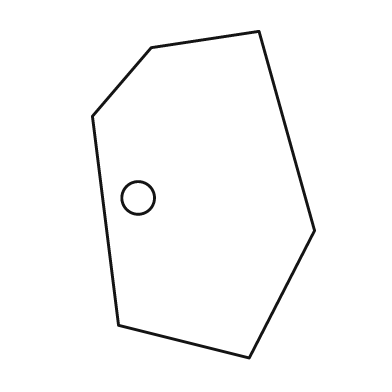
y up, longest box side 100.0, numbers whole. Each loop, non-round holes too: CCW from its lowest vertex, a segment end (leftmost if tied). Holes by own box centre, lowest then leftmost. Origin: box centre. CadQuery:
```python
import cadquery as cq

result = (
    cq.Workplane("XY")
    .moveTo(14.0, -50.0)
    .lineTo(34.0, -11.0)
    .lineTo(17.0, 50.0)
    .lineTo(-16.0, 45.0)
    .lineTo(-34.0, 24.0)
    .lineTo(-26.0, -40.0)
    .close()
    .moveTo(-20.0, -1.0)
    .circle(5.0)
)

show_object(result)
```